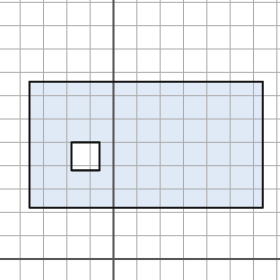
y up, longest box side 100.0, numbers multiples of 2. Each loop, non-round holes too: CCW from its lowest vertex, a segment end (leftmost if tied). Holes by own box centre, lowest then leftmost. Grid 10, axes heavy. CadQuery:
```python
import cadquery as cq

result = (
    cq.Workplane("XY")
    .moveTo(-36.0, 22.0)
    .lineTo(64.0, 22.0)
    .lineTo(64.0, 76.0)
    .lineTo(-36.0, 76.0)
    .close()
    .moveTo(-18.0, 38.0)
    .lineTo(-6.0, 38.0)
    .lineTo(-6.0, 50.0)
    .lineTo(-18.0, 50.0)
    .close()
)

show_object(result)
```